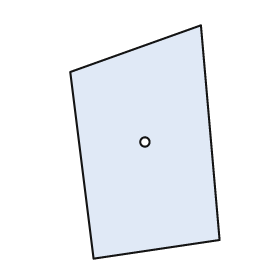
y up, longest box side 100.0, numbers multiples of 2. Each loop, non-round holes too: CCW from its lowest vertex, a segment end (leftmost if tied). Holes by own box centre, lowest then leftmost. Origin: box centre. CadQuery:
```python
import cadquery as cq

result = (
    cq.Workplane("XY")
    .moveTo(-22.0, -50.0)
    .lineTo(32.0, -42.0)
    .lineTo(24.0, 50.0)
    .lineTo(-32.0, 30.0)
    .close()
    .moveTo(0.0, 0.0)
    .circle(2.0)
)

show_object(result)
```